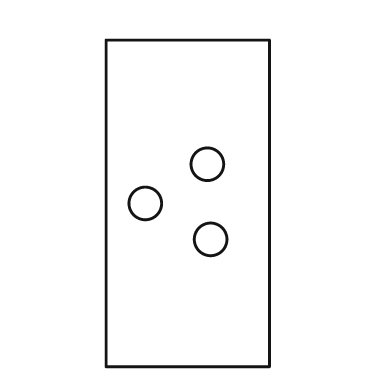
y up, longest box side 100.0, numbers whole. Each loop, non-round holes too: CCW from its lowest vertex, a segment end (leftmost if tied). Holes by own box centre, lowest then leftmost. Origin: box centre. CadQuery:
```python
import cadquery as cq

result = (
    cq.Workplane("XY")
    .moveTo(-25.0, -50.0)
    .lineTo(25.0, -50.0)
    .lineTo(25.0, 50.0)
    .lineTo(-25.0, 50.0)
    .close()
    .moveTo(7.0, -11.0)
    .circle(5.0)
    .moveTo(-13.0, 0.0)
    .circle(5.0)
    .moveTo(6.0, 12.0)
    .circle(5.0)
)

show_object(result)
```